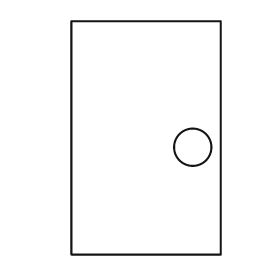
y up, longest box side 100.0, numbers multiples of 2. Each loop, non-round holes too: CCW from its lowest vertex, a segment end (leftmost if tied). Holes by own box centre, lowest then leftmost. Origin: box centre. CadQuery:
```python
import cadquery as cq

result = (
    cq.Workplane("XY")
    .moveTo(-32.0, -50.0)
    .lineTo(32.0, -50.0)
    .lineTo(32.0, 50.0)
    .lineTo(-32.0, 50.0)
    .close()
    .moveTo(20.0, -4.0)
    .circle(8.0)
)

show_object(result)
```